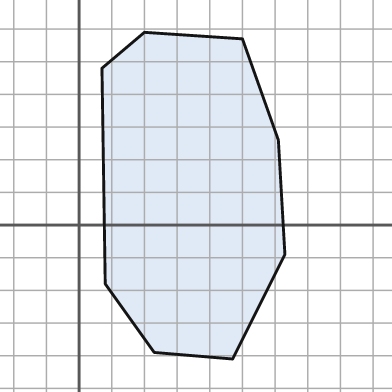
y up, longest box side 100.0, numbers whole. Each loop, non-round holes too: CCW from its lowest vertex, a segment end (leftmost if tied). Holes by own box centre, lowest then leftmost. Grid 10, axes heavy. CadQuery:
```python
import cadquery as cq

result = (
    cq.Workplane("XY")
    .moveTo(47.0, -41.0)
    .lineTo(63.0, -9.0)
    .lineTo(61.0, 26.0)
    .lineTo(50.0, 57.0)
    .lineTo(20.0, 59.0)
    .lineTo(7.0, 48.0)
    .lineTo(8.0, -18.0)
    .lineTo(23.0, -39.0)
    .close()
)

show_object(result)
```